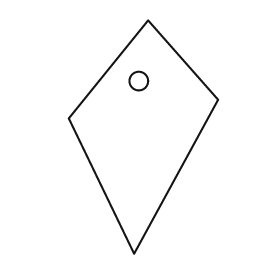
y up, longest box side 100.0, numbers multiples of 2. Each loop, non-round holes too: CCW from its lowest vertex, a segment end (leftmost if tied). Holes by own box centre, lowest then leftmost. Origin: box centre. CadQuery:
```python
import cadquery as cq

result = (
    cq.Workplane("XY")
    .moveTo(-4.0, -50.0)
    .lineTo(32.0, 16.0)
    .lineTo(2.0, 50.0)
    .lineTo(-32.0, 8.0)
    .close()
    .moveTo(-2.0, 24.0)
    .circle(4.0)
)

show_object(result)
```